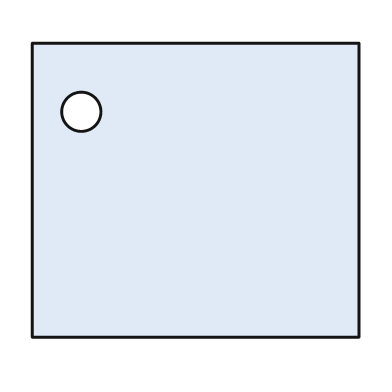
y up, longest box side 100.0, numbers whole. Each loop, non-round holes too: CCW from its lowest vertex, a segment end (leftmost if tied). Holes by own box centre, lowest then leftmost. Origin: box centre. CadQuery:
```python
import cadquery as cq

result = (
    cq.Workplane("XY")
    .moveTo(-50.0, -45.0)
    .lineTo(50.0, -45.0)
    .lineTo(50.0, 45.0)
    .lineTo(-50.0, 45.0)
    .close()
    .moveTo(-35.0, 24.0)
    .circle(6.0)
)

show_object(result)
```